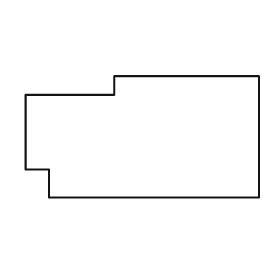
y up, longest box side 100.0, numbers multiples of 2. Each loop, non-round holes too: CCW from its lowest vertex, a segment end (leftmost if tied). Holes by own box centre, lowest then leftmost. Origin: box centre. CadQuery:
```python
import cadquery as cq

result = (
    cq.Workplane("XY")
    .moveTo(-40.0, -26.0)
    .lineTo(50.0, -26.0)
    .lineTo(50.0, 26.0)
    .lineTo(-12.0, 26.0)
    .lineTo(-12.0, 18.0)
    .lineTo(-50.0, 18.0)
    .lineTo(-50.0, -14.0)
    .lineTo(-40.0, -14.0)
    .close()
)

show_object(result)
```